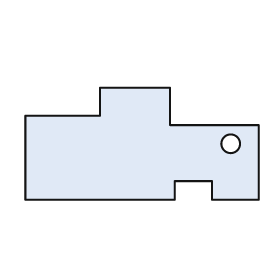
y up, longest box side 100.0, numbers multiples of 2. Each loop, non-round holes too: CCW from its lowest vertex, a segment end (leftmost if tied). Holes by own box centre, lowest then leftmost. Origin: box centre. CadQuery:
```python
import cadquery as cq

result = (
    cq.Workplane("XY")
    .moveTo(-50.0, -24.0)
    .lineTo(14.0, -24.0)
    .lineTo(14.0, -16.0)
    .lineTo(30.0, -16.0)
    .lineTo(30.0, -24.0)
    .lineTo(50.0, -24.0)
    .lineTo(50.0, 8.0)
    .lineTo(12.0, 8.0)
    .lineTo(12.0, 24.0)
    .lineTo(-18.0, 24.0)
    .lineTo(-18.0, 12.0)
    .lineTo(-50.0, 12.0)
    .close()
    .moveTo(38.0, 0.0)
    .circle(4.0)
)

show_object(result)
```